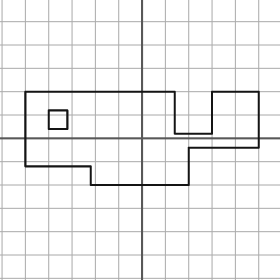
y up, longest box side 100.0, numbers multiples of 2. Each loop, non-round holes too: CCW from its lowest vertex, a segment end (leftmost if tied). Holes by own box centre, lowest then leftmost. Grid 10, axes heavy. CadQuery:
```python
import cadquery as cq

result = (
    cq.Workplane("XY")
    .moveTo(-22.0, -20.0)
    .lineTo(20.0, -20.0)
    .lineTo(20.0, -4.0)
    .lineTo(50.0, -4.0)
    .lineTo(50.0, 20.0)
    .lineTo(30.0, 20.0)
    .lineTo(30.0, 2.0)
    .lineTo(14.0, 2.0)
    .lineTo(14.0, 20.0)
    .lineTo(-50.0, 20.0)
    .lineTo(-50.0, -12.0)
    .lineTo(-22.0, -12.0)
    .close()
    .moveTo(-40.0, 4.0)
    .lineTo(-32.0, 4.0)
    .lineTo(-32.0, 12.0)
    .lineTo(-40.0, 12.0)
    .close()
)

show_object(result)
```